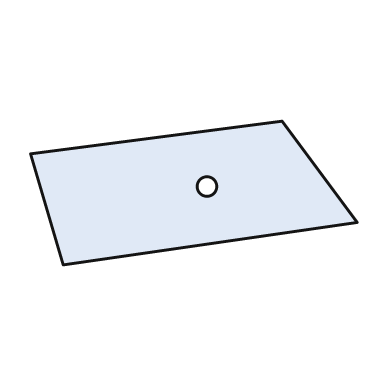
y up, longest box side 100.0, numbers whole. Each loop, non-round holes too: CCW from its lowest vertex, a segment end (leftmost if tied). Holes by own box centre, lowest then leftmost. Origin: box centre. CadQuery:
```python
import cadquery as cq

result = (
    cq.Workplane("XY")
    .moveTo(-40.0, -22.0)
    .lineTo(50.0, -9.0)
    .lineTo(27.0, 22.0)
    .lineTo(-50.0, 12.0)
    .close()
    .moveTo(4.0, 2.0)
    .circle(3.0)
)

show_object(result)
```